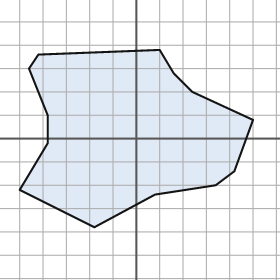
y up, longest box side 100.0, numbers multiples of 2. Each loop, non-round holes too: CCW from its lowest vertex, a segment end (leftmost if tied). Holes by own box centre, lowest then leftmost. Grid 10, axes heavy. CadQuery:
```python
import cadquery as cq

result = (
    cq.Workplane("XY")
    .moveTo(-18.0, -38.0)
    .lineTo(8.0, -24.0)
    .lineTo(34.0, -20.0)
    .lineTo(42.0, -14.0)
    .lineTo(50.0, 8.0)
    .lineTo(24.0, 20.0)
    .lineTo(16.0, 28.0)
    .lineTo(10.0, 38.0)
    .lineTo(-42.0, 36.0)
    .lineTo(-46.0, 30.0)
    .lineTo(-38.0, 10.0)
    .lineTo(-38.0, -2.0)
    .lineTo(-50.0, -22.0)
    .close()
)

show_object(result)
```